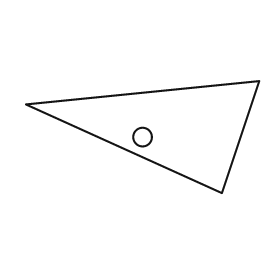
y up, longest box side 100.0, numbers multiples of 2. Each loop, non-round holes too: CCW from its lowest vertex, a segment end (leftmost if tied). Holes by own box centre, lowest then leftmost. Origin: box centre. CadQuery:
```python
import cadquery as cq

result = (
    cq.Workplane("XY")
    .moveTo(34.0, -24.0)
    .lineTo(50.0, 24.0)
    .lineTo(-50.0, 14.0)
    .close()
    .moveTo(0.0, 0.0)
    .circle(4.0)
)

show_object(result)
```